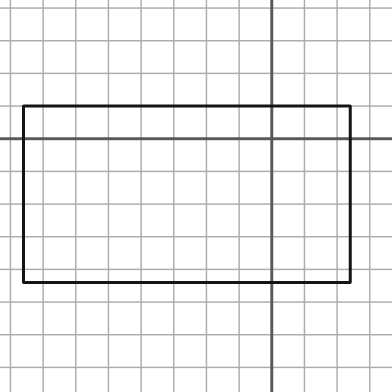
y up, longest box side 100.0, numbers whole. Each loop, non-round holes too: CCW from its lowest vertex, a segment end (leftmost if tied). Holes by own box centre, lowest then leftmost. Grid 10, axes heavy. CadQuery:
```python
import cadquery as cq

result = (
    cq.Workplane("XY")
    .moveTo(-76.0, -44.0)
    .lineTo(24.0, -44.0)
    .lineTo(24.0, 10.0)
    .lineTo(-76.0, 10.0)
    .close()
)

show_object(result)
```